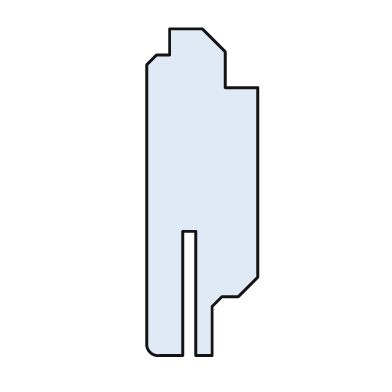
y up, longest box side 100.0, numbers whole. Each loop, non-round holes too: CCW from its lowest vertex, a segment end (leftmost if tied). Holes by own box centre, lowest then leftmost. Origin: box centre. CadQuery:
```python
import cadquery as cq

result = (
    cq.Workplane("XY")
    .moveTo(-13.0, -50.0)
    .lineTo(-6.0, -50.0)
    .lineTo(-6.0, -12.0)
    .lineTo(-2.0, -12.0)
    .lineTo(-2.0, -50.0)
    .lineTo(3.0, -50.0)
    .lineTo(3.0, -35.0)
    .lineTo(6.0, -32.0)
    .lineTo(11.0, -32.0)
    .lineTo(17.0, -26.0)
    .lineTo(17.0, 32.0)
    .lineTo(7.0, 32.0)
    .lineTo(7.0, 43.0)
    .lineTo(0.0, 50.0)
    .lineTo(-10.0, 50.0)
    .lineTo(-10.0, 42.0)
    .lineTo(-14.0, 42.0)
    .lineTo(-17.0, 39.0)
    .lineTo(-17.0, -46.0)
    .threePointArc((-16.0, -49.0), (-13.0, -50.0))
    .close()
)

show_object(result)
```